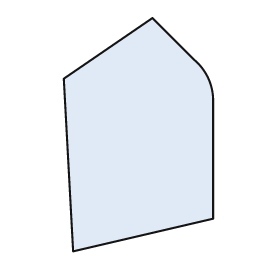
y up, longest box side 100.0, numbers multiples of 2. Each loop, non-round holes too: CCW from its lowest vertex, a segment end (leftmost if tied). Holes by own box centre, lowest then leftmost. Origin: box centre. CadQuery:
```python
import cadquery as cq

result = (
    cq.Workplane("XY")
    .moveTo(-28.0, -50.0)
    .lineTo(32.0, -36.0)
    .lineTo(32.0, 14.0)
    .threePointArc((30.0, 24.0), (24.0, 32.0))
    .lineTo(6.0, 50.0)
    .lineTo(-32.0, 24.0)
    .close()
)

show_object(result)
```